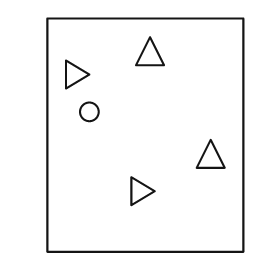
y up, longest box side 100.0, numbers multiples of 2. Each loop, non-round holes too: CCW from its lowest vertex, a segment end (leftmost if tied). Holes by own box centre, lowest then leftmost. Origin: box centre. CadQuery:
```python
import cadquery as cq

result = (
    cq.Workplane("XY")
    .moveTo(-42.0, -50.0)
    .lineTo(42.0, -50.0)
    .lineTo(42.0, 50.0)
    .lineTo(-42.0, 50.0)
    .close()
    .moveTo(-6.0, -30.0)
    .lineTo(4.0, -24.0)
    .lineTo(-6.0, -18.0)
    .close()
    .moveTo(22.0, -14.0)
    .lineTo(34.0, -14.0)
    .lineTo(28.0, -2.0)
    .close()
    .moveTo(-24.0, 10.0)
    .circle(4.0)
    .moveTo(-34.0, 20.0)
    .lineTo(-24.0, 26.0)
    .lineTo(-34.0, 32.0)
    .close()
    .moveTo(-4.0, 30.0)
    .lineTo(8.0, 30.0)
    .lineTo(2.0, 42.0)
    .close()
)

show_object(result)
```